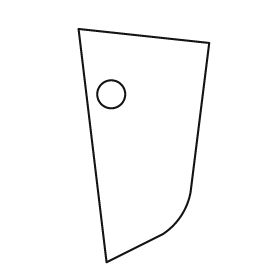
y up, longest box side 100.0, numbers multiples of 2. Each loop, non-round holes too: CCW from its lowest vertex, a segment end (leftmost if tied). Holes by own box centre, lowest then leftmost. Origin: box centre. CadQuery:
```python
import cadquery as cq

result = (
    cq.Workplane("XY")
    .moveTo(-16.0, -50.0)
    .lineTo(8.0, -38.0)
    .threePointArc((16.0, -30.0), (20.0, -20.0))
    .lineTo(28.0, 44.0)
    .lineTo(-28.0, 50.0)
    .close()
    .moveTo(-14.0, 22.0)
    .circle(6.0)
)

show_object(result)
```